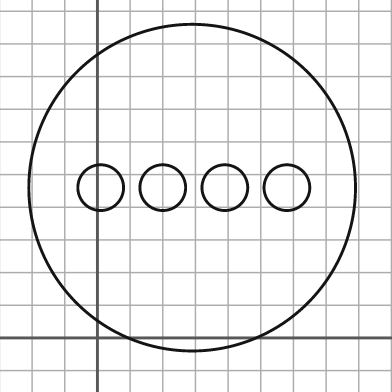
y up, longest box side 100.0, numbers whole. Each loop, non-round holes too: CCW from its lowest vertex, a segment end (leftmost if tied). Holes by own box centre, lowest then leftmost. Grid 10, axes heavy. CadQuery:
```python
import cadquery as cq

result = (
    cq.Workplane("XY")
    .moveTo(29.0, 46.0)
    .circle(50.0)
    .moveTo(1.0, 46.0)
    .circle(7.0)
    .moveTo(20.0, 46.0)
    .circle(7.0)
    .moveTo(39.0, 46.0)
    .circle(7.0)
    .moveTo(58.0, 46.0)
    .circle(7.0)
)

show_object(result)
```